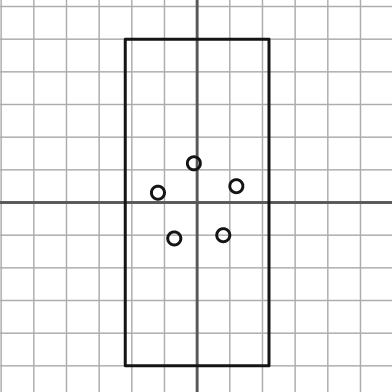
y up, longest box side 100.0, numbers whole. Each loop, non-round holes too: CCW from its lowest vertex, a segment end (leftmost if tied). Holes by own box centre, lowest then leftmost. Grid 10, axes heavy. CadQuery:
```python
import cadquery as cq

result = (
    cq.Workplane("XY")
    .moveTo(-22.0, -50.0)
    .lineTo(22.0, -50.0)
    .lineTo(22.0, 50.0)
    .lineTo(-22.0, 50.0)
    .close()
    .moveTo(-7.0, -11.0)
    .circle(2.0)
    .moveTo(8.0, -10.0)
    .circle(2.0)
    .moveTo(-12.0, 3.0)
    .circle(2.0)
    .moveTo(12.0, 5.0)
    .circle(2.0)
    .moveTo(-1.0, 12.0)
    .circle(2.0)
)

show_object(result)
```